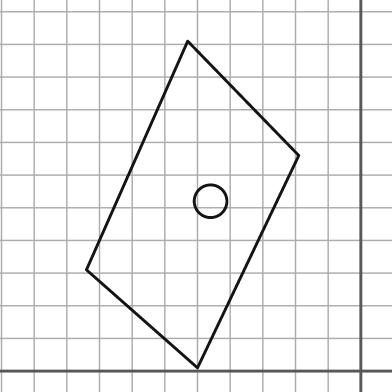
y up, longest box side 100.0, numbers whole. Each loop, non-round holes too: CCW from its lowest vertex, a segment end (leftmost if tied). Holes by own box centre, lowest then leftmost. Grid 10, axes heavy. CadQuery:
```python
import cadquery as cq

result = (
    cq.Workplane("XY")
    .moveTo(-50.0, 1.0)
    .lineTo(-19.0, 66.0)
    .lineTo(-53.0, 101.0)
    .lineTo(-84.0, 31.0)
    .close()
    .moveTo(-46.0, 52.0)
    .circle(5.0)
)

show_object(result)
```